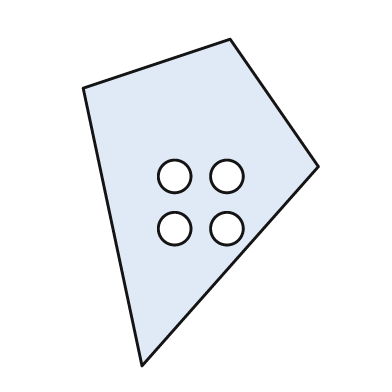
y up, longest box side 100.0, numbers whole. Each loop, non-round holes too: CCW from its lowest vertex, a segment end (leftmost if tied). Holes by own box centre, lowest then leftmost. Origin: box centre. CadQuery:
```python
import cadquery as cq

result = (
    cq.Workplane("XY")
    .moveTo(-18.0, -50.0)
    .lineTo(36.0, 11.0)
    .lineTo(9.0, 50.0)
    .lineTo(-36.0, 35.0)
    .close()
    .moveTo(-8.0, -8.0)
    .circle(5.0)
    .moveTo(8.0, -8.0)
    .circle(5.0)
    .moveTo(-8.0, 8.0)
    .circle(5.0)
    .moveTo(8.0, 8.0)
    .circle(5.0)
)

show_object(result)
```